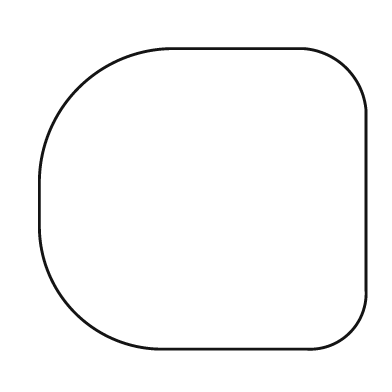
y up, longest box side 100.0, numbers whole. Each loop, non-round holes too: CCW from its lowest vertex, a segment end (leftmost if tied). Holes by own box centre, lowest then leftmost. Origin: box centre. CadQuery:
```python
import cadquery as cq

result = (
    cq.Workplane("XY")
    .moveTo(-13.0, -46.0)
    .lineTo(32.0, -46.0)
    .threePointArc((45.0, -41.0), (50.0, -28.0))
    .lineTo(50.0, 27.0)
    .threePointArc((44.0, 40.0), (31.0, 46.0))
    .lineTo(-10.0, 46.0)
    .threePointArc((-38.0, 34.0), (-50.0, 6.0))
    .lineTo(-50.0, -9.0)
    .threePointArc((-39.0, -35.0), (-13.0, -46.0))
    .close()
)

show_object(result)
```